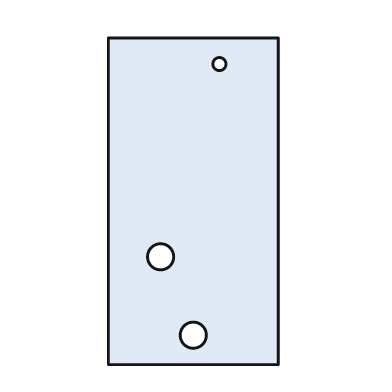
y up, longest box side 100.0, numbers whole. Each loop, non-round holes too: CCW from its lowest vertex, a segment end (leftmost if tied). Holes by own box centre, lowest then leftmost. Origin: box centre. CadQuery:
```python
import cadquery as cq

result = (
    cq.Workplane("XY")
    .moveTo(-26.0, -50.0)
    .lineTo(26.0, -50.0)
    .lineTo(26.0, 50.0)
    .lineTo(-26.0, 50.0)
    .close()
    .moveTo(0.0, -41.0)
    .circle(4.0)
    .moveTo(-10.0, -17.0)
    .circle(4.0)
    .moveTo(8.0, 42.0)
    .circle(2.0)
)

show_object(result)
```